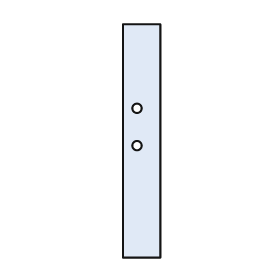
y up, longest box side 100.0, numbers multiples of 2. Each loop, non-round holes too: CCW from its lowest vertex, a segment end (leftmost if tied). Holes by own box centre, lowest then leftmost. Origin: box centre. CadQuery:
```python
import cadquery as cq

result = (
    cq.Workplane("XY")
    .moveTo(-8.0, -50.0)
    .lineTo(8.0, -50.0)
    .lineTo(8.0, 50.0)
    .lineTo(-8.0, 50.0)
    .close()
    .moveTo(-2.0, -2.0)
    .circle(2.0)
    .moveTo(-2.0, 14.0)
    .circle(2.0)
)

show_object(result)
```